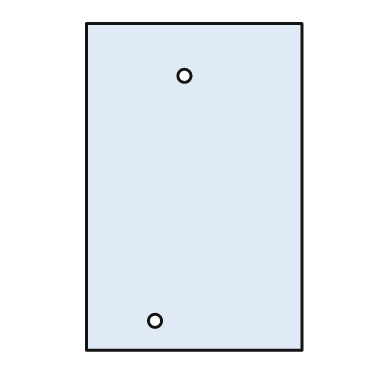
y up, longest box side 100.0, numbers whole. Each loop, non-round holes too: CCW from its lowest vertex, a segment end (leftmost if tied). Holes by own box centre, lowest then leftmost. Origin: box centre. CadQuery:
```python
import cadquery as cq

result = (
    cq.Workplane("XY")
    .moveTo(-33.0, -50.0)
    .lineTo(33.0, -50.0)
    .lineTo(33.0, 50.0)
    .lineTo(-33.0, 50.0)
    .close()
    .moveTo(-12.0, -41.0)
    .circle(2.0)
    .moveTo(-3.0, 34.0)
    .circle(2.0)
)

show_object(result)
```